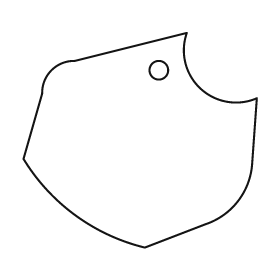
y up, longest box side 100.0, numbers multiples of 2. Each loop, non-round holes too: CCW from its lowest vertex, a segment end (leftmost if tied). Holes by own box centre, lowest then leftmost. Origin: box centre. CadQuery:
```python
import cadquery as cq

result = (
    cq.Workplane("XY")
    .moveTo(2.0, -46.0)
    .lineTo(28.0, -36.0)
    .threePointArc((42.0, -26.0), (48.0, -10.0))
    .lineTo(50.0, 18.0)
    .threePointArc((26.0, 22.0), (20.0, 46.0))
    .lineTo(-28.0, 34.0)
    .threePointArc((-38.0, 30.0), (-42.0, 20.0))
    .lineTo(-50.0, -8.0)
    .threePointArc((-28.0, -32.0), (2.0, -46.0))
    .close()
    .moveTo(8.0, 30.0)
    .circle(4.0)
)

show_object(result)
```